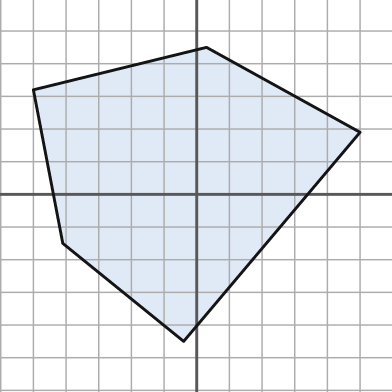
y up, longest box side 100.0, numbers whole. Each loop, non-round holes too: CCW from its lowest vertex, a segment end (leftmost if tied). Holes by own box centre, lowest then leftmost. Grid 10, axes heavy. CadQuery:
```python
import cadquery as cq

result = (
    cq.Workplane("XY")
    .moveTo(-4.0, -45.0)
    .lineTo(50.0, 19.0)
    .lineTo(3.0, 45.0)
    .lineTo(-50.0, 32.0)
    .lineTo(-41.0, -15.0)
    .close()
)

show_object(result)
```